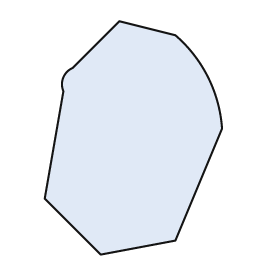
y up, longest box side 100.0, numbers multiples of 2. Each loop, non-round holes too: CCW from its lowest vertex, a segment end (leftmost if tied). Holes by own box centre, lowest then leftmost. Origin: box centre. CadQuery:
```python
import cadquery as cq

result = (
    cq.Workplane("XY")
    .moveTo(-14.0, -50.0)
    .lineTo(18.0, -44.0)
    .lineTo(38.0, 4.0)
    .threePointArc((32.0, 26.0), (18.0, 44.0))
    .lineTo(-6.0, 50.0)
    .lineTo(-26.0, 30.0)
    .threePointArc((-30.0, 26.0), (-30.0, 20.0))
    .lineTo(-38.0, -26.0)
    .close()
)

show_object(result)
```